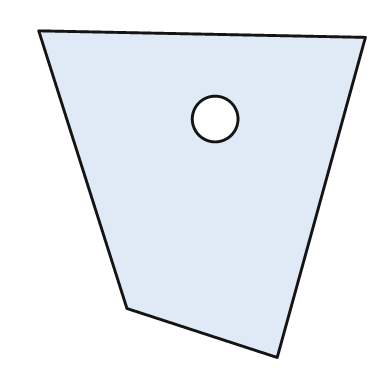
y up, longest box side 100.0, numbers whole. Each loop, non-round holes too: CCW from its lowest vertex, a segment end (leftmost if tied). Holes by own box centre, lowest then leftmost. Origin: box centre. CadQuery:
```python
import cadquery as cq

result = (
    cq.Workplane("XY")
    .moveTo(23.0, -50.0)
    .lineTo(50.0, 48.0)
    .lineTo(-50.0, 50.0)
    .lineTo(-23.0, -35.0)
    .close()
    .moveTo(4.0, 23.0)
    .circle(7.0)
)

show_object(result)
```